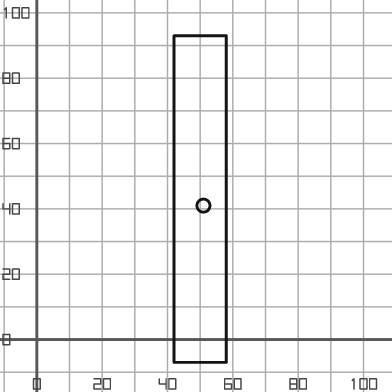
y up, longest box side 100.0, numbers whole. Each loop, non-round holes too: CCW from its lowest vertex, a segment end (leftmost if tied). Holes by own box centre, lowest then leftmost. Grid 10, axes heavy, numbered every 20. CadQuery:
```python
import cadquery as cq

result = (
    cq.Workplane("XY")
    .moveTo(42.0, -7.0)
    .lineTo(58.0, -7.0)
    .lineTo(58.0, 93.0)
    .lineTo(42.0, 93.0)
    .close()
    .moveTo(51.0, 41.0)
    .circle(2.0)
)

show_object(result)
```